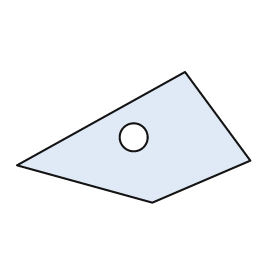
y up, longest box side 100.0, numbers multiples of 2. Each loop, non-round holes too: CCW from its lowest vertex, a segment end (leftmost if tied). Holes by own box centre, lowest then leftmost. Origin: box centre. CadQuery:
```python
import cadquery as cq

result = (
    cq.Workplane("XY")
    .moveTo(8.0, -28.0)
    .lineTo(50.0, -10.0)
    .lineTo(22.0, 28.0)
    .lineTo(-50.0, -12.0)
    .close()
    .moveTo(0.0, 0.0)
    .circle(6.0)
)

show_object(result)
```